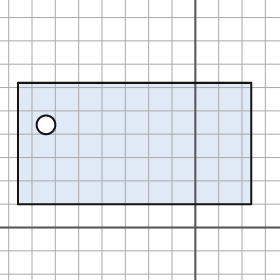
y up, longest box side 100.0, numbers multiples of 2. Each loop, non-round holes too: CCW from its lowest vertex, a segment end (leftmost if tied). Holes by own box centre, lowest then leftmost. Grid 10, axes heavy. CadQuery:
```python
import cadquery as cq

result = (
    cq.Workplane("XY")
    .moveTo(-76.0, 10.0)
    .lineTo(24.0, 10.0)
    .lineTo(24.0, 62.0)
    .lineTo(-76.0, 62.0)
    .close()
    .moveTo(-64.0, 44.0)
    .circle(4.0)
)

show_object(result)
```